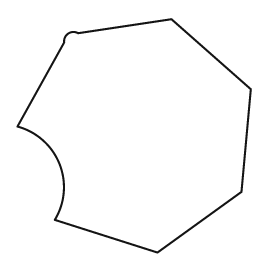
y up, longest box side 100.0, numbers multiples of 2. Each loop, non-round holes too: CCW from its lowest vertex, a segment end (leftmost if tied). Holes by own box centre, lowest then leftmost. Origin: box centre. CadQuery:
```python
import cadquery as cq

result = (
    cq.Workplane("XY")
    .moveTo(10.0, -50.0)
    .lineTo(46.0, -24.0)
    .lineTo(50.0, 20.0)
    .lineTo(16.0, 50.0)
    .lineTo(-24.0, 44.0)
    .threePointArc((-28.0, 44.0), (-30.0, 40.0))
    .lineTo(-50.0, 4.0)
    .threePointArc((-32.0, -12.0), (-34.0, -36.0))
    .close()
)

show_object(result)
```